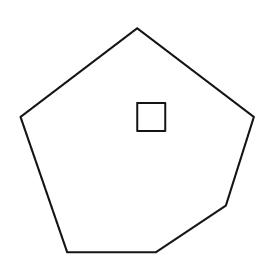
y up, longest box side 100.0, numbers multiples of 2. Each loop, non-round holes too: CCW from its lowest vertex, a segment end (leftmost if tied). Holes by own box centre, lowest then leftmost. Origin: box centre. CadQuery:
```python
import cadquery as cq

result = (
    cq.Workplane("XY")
    .moveTo(-30.0, -48.0)
    .lineTo(8.0, -48.0)
    .lineTo(38.0, -28.0)
    .lineTo(50.0, 10.0)
    .lineTo(0.0, 48.0)
    .lineTo(-50.0, 10.0)
    .close()
    .moveTo(0.0, 4.0)
    .lineTo(12.0, 4.0)
    .lineTo(12.0, 16.0)
    .lineTo(0.0, 16.0)
    .close()
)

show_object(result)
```